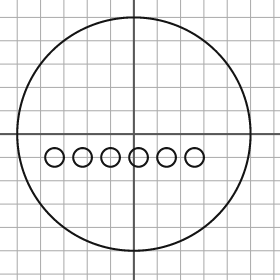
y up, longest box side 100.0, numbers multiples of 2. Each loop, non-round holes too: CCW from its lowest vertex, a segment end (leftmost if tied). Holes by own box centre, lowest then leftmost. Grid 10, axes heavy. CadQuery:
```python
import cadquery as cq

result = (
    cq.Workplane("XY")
    .moveTo(0.0, 0.0)
    .circle(50.0)
    .moveTo(-34.0, -10.0)
    .circle(4.0)
    .moveTo(-22.0, -10.0)
    .circle(4.0)
    .moveTo(-10.0, -10.0)
    .circle(4.0)
    .moveTo(2.0, -10.0)
    .circle(4.0)
    .moveTo(14.0, -10.0)
    .circle(4.0)
    .moveTo(26.0, -10.0)
    .circle(4.0)
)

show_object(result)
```